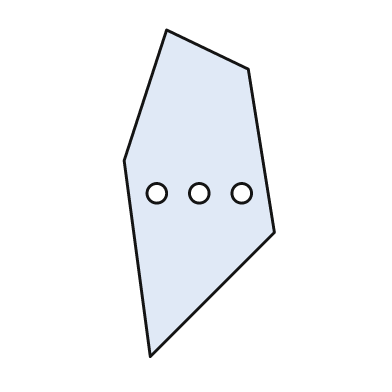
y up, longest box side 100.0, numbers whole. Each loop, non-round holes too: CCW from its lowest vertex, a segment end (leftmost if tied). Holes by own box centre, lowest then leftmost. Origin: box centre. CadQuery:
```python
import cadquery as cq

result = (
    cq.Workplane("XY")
    .moveTo(-15.0, -50.0)
    .lineTo(23.0, -12.0)
    .lineTo(15.0, 38.0)
    .lineTo(-10.0, 50.0)
    .lineTo(-23.0, 10.0)
    .close()
    .moveTo(-13.0, 0.0)
    .circle(3.0)
    .moveTo(0.0, 0.0)
    .circle(3.0)
    .moveTo(13.0, 0.0)
    .circle(3.0)
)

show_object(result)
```